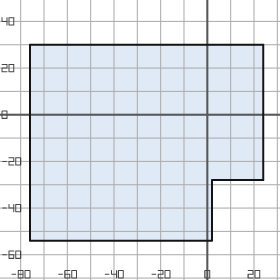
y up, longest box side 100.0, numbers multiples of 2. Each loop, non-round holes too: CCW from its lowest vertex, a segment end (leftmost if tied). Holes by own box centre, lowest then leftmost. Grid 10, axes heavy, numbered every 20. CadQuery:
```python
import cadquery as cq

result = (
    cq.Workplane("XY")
    .moveTo(-76.0, -54.0)
    .lineTo(2.0, -54.0)
    .lineTo(2.0, -28.0)
    .lineTo(24.0, -28.0)
    .lineTo(24.0, 30.0)
    .lineTo(-76.0, 30.0)
    .close()
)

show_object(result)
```